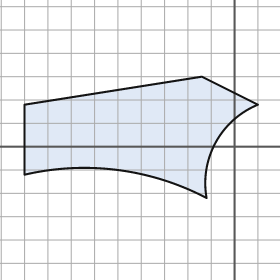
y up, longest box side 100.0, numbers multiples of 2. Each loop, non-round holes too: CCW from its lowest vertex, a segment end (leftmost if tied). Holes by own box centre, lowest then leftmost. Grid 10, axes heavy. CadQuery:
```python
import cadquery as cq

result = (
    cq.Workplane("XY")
    .moveTo(-12.0, -22.0)
    .threePointArc((-8.0, 2.0), (10.0, 18.0))
    .lineTo(-14.0, 30.0)
    .lineTo(-90.0, 18.0)
    .lineTo(-90.0, -12.0)
    .threePointArc((-50.0, -10.0), (-12.0, -22.0))
    .close()
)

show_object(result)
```